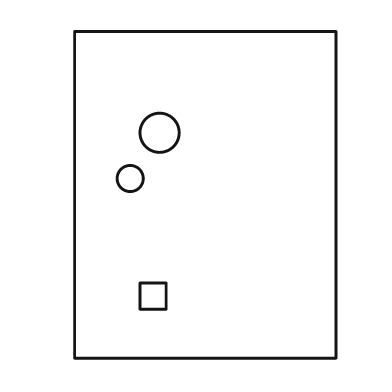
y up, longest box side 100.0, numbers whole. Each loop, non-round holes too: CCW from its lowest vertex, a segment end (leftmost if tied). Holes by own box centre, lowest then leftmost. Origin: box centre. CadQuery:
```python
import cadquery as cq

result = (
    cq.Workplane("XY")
    .moveTo(-40.0, -50.0)
    .lineTo(40.0, -50.0)
    .lineTo(40.0, 50.0)
    .lineTo(-40.0, 50.0)
    .close()
    .moveTo(-20.0, -35.0)
    .lineTo(-12.0, -35.0)
    .lineTo(-12.0, -27.0)
    .lineTo(-20.0, -27.0)
    .close()
    .moveTo(-23.0, 5.0)
    .circle(4.0)
    .moveTo(-14.0, 19.0)
    .circle(6.0)
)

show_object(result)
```